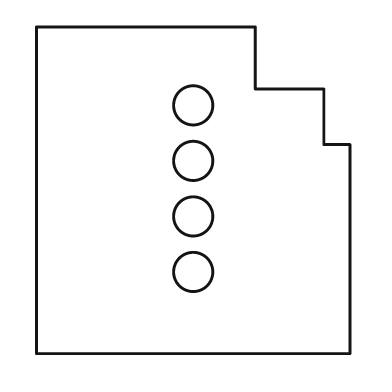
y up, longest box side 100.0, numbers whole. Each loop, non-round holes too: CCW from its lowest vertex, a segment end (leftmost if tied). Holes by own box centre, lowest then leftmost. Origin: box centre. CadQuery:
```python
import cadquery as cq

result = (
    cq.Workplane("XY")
    .moveTo(-48.0, -50.0)
    .lineTo(48.0, -50.0)
    .lineTo(48.0, 14.0)
    .lineTo(40.0, 14.0)
    .lineTo(40.0, 31.0)
    .lineTo(19.0, 31.0)
    .lineTo(19.0, 50.0)
    .lineTo(-48.0, 50.0)
    .close()
    .moveTo(0.0, -25.0)
    .circle(6.0)
    .moveTo(0.0, -8.0)
    .circle(6.0)
    .moveTo(0.0, 9.0)
    .circle(6.0)
    .moveTo(0.0, 26.0)
    .circle(6.0)
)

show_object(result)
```